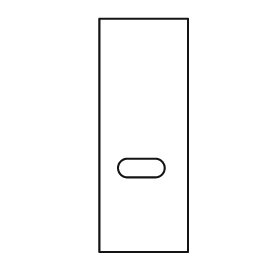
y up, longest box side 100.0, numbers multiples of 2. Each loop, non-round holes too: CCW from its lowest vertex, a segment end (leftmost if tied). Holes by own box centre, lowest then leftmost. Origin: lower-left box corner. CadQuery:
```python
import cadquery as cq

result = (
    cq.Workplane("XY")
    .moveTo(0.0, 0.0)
    .lineTo(38.0, 0.0)
    .lineTo(38.0, 100.0)
    .lineTo(0.0, 100.0)
    .close()
    .moveTo(12.0, 32.0)
    .lineTo(24.0, 32.0)
    .threePointArc((28.0, 36.0), (24.0, 40.0))
    .lineTo(12.0, 40.0)
    .threePointArc((8.0, 36.0), (12.0, 32.0))
    .close()
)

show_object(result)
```